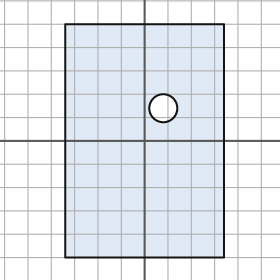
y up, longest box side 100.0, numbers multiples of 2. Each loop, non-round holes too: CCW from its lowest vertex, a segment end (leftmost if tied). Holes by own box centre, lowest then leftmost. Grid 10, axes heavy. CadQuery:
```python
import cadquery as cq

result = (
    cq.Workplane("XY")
    .moveTo(-34.0, -50.0)
    .lineTo(34.0, -50.0)
    .lineTo(34.0, 50.0)
    .lineTo(-34.0, 50.0)
    .close()
    .moveTo(8.0, 14.0)
    .circle(6.0)
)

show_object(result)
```